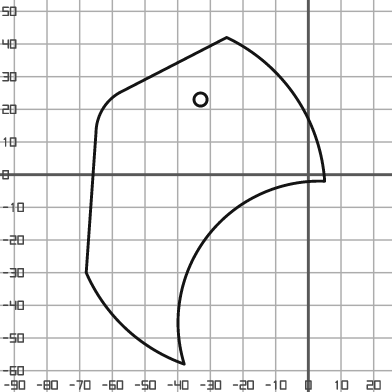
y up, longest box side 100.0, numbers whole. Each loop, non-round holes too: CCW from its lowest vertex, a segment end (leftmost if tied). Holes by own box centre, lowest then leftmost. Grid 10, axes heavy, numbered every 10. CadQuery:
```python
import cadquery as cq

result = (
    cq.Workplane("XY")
    .moveTo(-38.0, -58.0)
    .threePointArc((-31.0, -19.0), (5.0, -2.0))
    .threePointArc((-4.0, 24.0), (-25.0, 42.0))
    .lineTo(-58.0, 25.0)
    .threePointArc((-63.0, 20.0), (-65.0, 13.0))
    .lineTo(-68.0, -30.0)
    .threePointArc((-56.0, -47.0), (-38.0, -58.0))
    .close()
    .moveTo(-33.0, 23.0)
    .circle(2.0)
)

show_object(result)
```